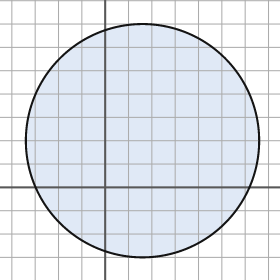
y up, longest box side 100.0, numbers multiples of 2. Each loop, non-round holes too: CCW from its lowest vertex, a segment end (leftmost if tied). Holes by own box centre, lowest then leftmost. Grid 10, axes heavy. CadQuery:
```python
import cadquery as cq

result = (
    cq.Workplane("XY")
    .moveTo(16.0, 20.0)
    .circle(50.0)
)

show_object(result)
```